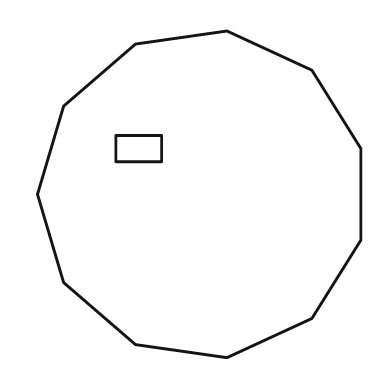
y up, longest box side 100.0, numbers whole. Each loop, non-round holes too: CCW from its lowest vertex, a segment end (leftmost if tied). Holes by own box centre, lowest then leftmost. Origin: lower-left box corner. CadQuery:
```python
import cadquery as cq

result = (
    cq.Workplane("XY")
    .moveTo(58.0, 0.0)
    .lineTo(84.0, 12.0)
    .lineTo(99.0, 36.0)
    .lineTo(99.0, 64.0)
    .lineTo(84.0, 88.0)
    .lineTo(58.0, 100.0)
    .lineTo(30.0, 96.0)
    .lineTo(8.0, 77.0)
    .lineTo(0.0, 50.0)
    .lineTo(8.0, 23.0)
    .lineTo(30.0, 4.0)
    .close()
    .moveTo(24.0, 60.0)
    .lineTo(38.0, 60.0)
    .lineTo(38.0, 68.0)
    .lineTo(24.0, 68.0)
    .close()
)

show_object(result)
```